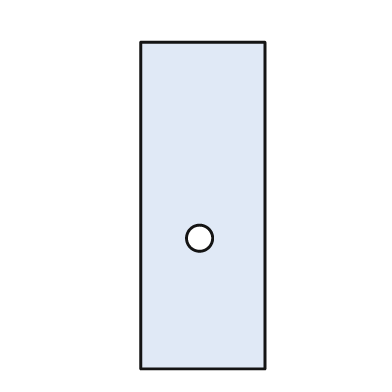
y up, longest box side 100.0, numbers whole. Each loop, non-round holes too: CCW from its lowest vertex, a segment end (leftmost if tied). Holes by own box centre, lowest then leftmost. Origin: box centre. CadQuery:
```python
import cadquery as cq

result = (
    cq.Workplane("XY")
    .moveTo(-19.0, -50.0)
    .lineTo(19.0, -50.0)
    .lineTo(19.0, 50.0)
    .lineTo(-19.0, 50.0)
    .close()
    .moveTo(-1.0, -10.0)
    .circle(4.0)
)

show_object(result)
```